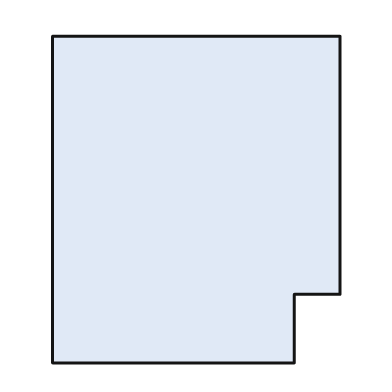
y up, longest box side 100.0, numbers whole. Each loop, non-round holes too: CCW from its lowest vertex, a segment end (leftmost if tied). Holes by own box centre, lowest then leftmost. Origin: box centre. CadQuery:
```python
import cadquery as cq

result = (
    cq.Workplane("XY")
    .moveTo(-44.0, -50.0)
    .lineTo(30.0, -50.0)
    .lineTo(30.0, -29.0)
    .lineTo(44.0, -29.0)
    .lineTo(44.0, 50.0)
    .lineTo(-44.0, 50.0)
    .close()
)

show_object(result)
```